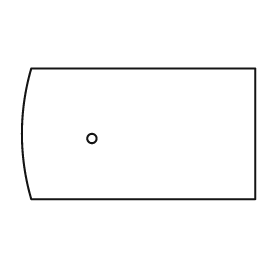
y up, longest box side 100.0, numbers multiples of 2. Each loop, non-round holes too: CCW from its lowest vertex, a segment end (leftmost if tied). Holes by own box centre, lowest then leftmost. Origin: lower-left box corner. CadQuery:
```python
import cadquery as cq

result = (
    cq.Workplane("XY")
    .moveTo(4.0, 0.0)
    .lineTo(100.0, 0.0)
    .lineTo(100.0, 56.0)
    .lineTo(4.0, 56.0)
    .threePointArc((0.0, 28.0), (4.0, 0.0))
    .close()
    .moveTo(30.0, 26.0)
    .circle(2.0)
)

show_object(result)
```